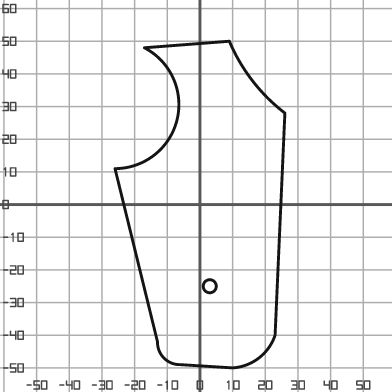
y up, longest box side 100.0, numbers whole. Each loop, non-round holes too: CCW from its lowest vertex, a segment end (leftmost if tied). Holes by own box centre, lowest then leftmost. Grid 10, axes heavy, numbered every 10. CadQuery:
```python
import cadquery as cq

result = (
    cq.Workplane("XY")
    .moveTo(10.0, -50.0)
    .threePointArc((18.0, -47.0), (23.0, -40.0))
    .lineTo(26.0, 28.0)
    .threePointArc((16.0, 38.0), (9.0, 50.0))
    .lineTo(-17.0, 48.0)
    .threePointArc((-7.0, 26.0), (-26.0, 11.0))
    .lineTo(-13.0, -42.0)
    .threePointArc((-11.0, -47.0), (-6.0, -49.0))
    .close()
    .moveTo(3.0, -25.0)
    .circle(2.0)
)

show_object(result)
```